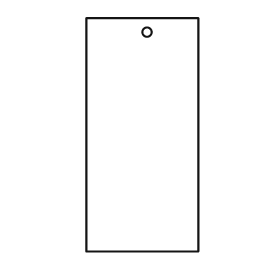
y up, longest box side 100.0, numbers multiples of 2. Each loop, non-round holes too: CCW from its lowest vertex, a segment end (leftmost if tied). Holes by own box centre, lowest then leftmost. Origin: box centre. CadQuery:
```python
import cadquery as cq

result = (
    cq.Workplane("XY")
    .moveTo(-24.0, -50.0)
    .lineTo(24.0, -50.0)
    .lineTo(24.0, 50.0)
    .lineTo(-24.0, 50.0)
    .close()
    .moveTo(2.0, 44.0)
    .circle(2.0)
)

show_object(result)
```